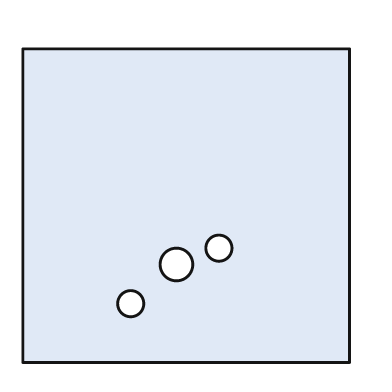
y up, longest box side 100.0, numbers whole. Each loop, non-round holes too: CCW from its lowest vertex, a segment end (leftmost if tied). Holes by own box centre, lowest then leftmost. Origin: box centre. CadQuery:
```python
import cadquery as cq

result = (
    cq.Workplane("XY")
    .moveTo(-50.0, -48.0)
    .lineTo(50.0, -48.0)
    .lineTo(50.0, 48.0)
    .lineTo(-50.0, 48.0)
    .close()
    .moveTo(-17.0, -30.0)
    .circle(4.0)
    .moveTo(-3.0, -18.0)
    .circle(5.0)
    .moveTo(10.0, -13.0)
    .circle(4.0)
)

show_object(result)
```